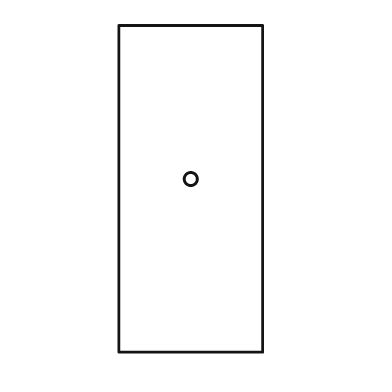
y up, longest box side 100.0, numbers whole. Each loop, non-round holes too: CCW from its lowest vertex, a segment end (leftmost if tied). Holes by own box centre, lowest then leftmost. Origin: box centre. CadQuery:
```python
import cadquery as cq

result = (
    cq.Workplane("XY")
    .moveTo(-22.0, -50.0)
    .lineTo(22.0, -50.0)
    .lineTo(22.0, 50.0)
    .lineTo(-22.0, 50.0)
    .close()
    .moveTo(0.0, 3.0)
    .circle(2.0)
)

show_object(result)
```